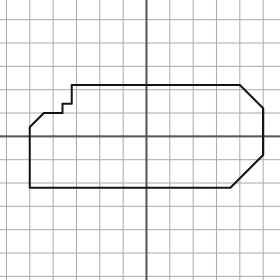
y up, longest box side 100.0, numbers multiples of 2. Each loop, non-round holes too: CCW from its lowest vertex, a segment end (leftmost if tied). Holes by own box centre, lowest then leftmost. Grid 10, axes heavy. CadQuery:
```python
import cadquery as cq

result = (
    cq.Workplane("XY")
    .moveTo(-50.0, -22.0)
    .lineTo(36.0, -22.0)
    .lineTo(50.0, -8.0)
    .lineTo(50.0, 12.0)
    .lineTo(40.0, 22.0)
    .lineTo(-32.0, 22.0)
    .lineTo(-32.0, 14.0)
    .lineTo(-36.0, 14.0)
    .lineTo(-36.0, 10.0)
    .lineTo(-44.0, 10.0)
    .lineTo(-50.0, 4.0)
    .close()
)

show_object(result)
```